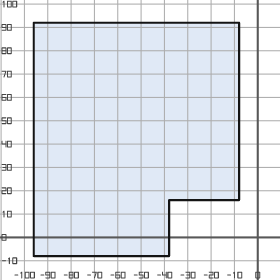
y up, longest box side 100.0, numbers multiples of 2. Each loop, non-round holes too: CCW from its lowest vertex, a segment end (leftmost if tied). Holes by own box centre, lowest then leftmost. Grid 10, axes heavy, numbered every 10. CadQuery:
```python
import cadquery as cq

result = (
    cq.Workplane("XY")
    .moveTo(-96.0, -8.0)
    .lineTo(-38.0, -8.0)
    .lineTo(-38.0, 16.0)
    .lineTo(-8.0, 16.0)
    .lineTo(-8.0, 92.0)
    .lineTo(-96.0, 92.0)
    .close()
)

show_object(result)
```